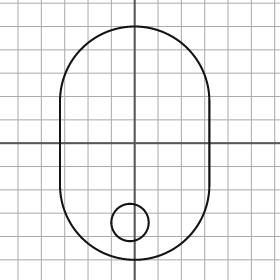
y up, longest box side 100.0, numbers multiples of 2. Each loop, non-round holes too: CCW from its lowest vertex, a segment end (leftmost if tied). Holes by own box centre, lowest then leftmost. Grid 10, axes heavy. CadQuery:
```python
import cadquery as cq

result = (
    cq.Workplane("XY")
    .moveTo(-32.0, -18.0)
    .threePointArc((0.0, -50.0), (32.0, -18.0))
    .lineTo(32.0, 18.0)
    .threePointArc((0.0, 50.0), (-32.0, 18.0))
    .close()
    .moveTo(-2.0, -34.0)
    .circle(8.0)
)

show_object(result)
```